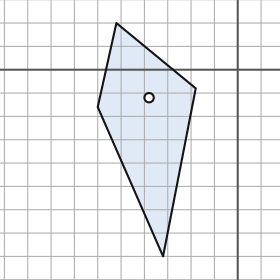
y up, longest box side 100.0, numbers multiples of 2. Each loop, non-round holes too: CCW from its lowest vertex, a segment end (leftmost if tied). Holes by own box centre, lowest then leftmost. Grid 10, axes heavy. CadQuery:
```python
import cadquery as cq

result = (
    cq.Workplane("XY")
    .moveTo(-32.0, -80.0)
    .lineTo(-18.0, -8.0)
    .lineTo(-52.0, 20.0)
    .lineTo(-60.0, -16.0)
    .close()
    .moveTo(-38.0, -12.0)
    .circle(2.0)
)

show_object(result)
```